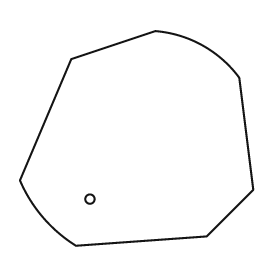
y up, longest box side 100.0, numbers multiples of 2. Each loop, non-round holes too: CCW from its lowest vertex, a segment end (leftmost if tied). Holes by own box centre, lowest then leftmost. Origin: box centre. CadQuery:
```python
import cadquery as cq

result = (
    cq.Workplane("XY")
    .moveTo(-26.0, -46.0)
    .lineTo(30.0, -42.0)
    .lineTo(50.0, -22.0)
    .lineTo(44.0, 26.0)
    .threePointArc((28.0, 40.0), (8.0, 46.0))
    .lineTo(-28.0, 34.0)
    .lineTo(-50.0, -18.0)
    .threePointArc((-40.0, -34.0), (-26.0, -46.0))
    .close()
    .moveTo(-20.0, -26.0)
    .circle(2.0)
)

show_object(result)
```